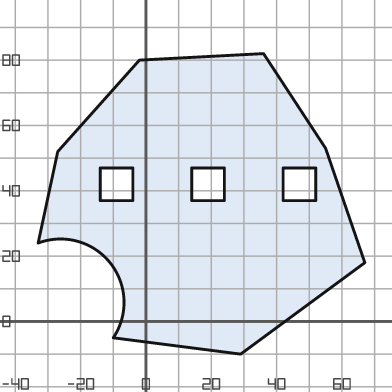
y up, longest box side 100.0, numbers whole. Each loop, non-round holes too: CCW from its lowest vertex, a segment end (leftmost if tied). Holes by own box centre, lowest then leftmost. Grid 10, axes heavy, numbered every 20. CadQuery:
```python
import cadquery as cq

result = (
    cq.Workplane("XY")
    .moveTo(29.0, -10.0)
    .lineTo(67.0, 18.0)
    .lineTo(55.0, 53.0)
    .lineTo(36.0, 82.0)
    .lineTo(-2.0, 80.0)
    .lineTo(-27.0, 52.0)
    .lineTo(-33.0, 24.0)
    .threePointArc((-11.0, 18.0), (-10.0, -5.0))
    .close()
    .moveTo(-14.0, 37.0)
    .lineTo(-4.0, 37.0)
    .lineTo(-4.0, 47.0)
    .lineTo(-14.0, 47.0)
    .close()
    .moveTo(14.0, 37.0)
    .lineTo(24.0, 37.0)
    .lineTo(24.0, 47.0)
    .lineTo(14.0, 47.0)
    .close()
    .moveTo(42.0, 37.0)
    .lineTo(52.0, 37.0)
    .lineTo(52.0, 47.0)
    .lineTo(42.0, 47.0)
    .close()
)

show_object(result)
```